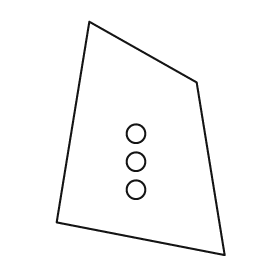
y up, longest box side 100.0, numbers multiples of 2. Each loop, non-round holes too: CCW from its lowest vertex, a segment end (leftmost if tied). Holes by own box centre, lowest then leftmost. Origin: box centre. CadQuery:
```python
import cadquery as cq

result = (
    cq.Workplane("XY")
    .moveTo(36.0, -50.0)
    .lineTo(24.0, 24.0)
    .lineTo(-22.0, 50.0)
    .lineTo(-36.0, -36.0)
    .close()
    .moveTo(-2.0, -22.0)
    .circle(4.0)
    .moveTo(-2.0, -10.0)
    .circle(4.0)
    .moveTo(-2.0, 2.0)
    .circle(4.0)
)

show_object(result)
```